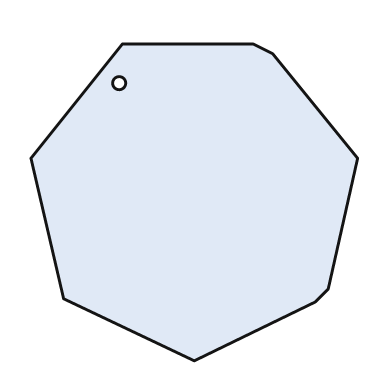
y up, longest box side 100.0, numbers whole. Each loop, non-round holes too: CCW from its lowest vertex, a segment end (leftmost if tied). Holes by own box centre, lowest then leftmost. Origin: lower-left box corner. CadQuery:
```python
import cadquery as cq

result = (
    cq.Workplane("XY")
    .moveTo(50.0, 0.0)
    .lineTo(87.0, 18.0)
    .lineTo(91.0, 22.0)
    .lineTo(100.0, 62.0)
    .lineTo(74.0, 94.0)
    .lineTo(68.0, 97.0)
    .lineTo(28.0, 97.0)
    .lineTo(0.0, 62.0)
    .lineTo(10.0, 19.0)
    .close()
    .moveTo(27.0, 85.0)
    .circle(2.0)
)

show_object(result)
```